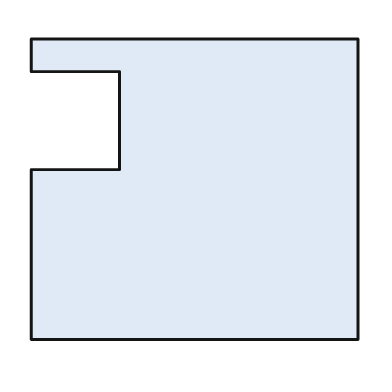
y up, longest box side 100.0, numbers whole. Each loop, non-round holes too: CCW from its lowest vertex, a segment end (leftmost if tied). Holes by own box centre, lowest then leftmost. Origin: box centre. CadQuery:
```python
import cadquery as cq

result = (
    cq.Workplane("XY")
    .moveTo(-50.0, -46.0)
    .lineTo(50.0, -46.0)
    .lineTo(50.0, 46.0)
    .lineTo(-50.0, 46.0)
    .lineTo(-50.0, 36.0)
    .lineTo(-23.0, 36.0)
    .lineTo(-23.0, 6.0)
    .lineTo(-50.0, 6.0)
    .close()
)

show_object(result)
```